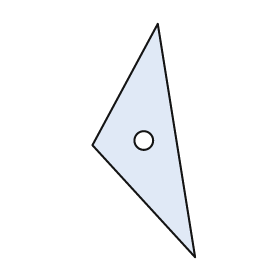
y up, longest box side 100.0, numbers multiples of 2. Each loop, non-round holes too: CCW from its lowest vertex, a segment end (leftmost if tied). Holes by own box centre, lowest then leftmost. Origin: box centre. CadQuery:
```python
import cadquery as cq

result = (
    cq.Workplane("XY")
    .moveTo(22.0, -50.0)
    .lineTo(6.0, 50.0)
    .lineTo(-22.0, -2.0)
    .close()
    .moveTo(0.0, 0.0)
    .circle(4.0)
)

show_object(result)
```